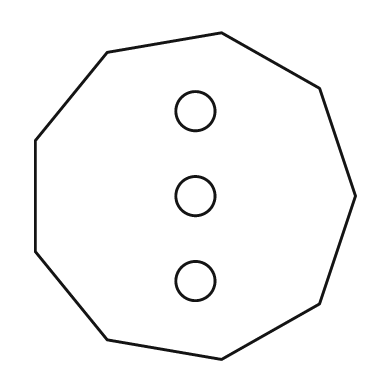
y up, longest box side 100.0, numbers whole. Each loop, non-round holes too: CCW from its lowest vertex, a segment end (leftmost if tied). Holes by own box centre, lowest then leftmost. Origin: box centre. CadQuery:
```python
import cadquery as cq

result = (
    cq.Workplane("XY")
    .moveTo(8.0, -50.0)
    .lineTo(38.0, -33.0)
    .lineTo(49.0, 0.0)
    .lineTo(38.0, 33.0)
    .lineTo(8.0, 50.0)
    .lineTo(-27.0, 44.0)
    .lineTo(-49.0, 17.0)
    .lineTo(-49.0, -17.0)
    .lineTo(-27.0, -44.0)
    .close()
    .moveTo(0.0, -26.0)
    .circle(6.0)
    .moveTo(0.0, 0.0)
    .circle(6.0)
    .moveTo(0.0, 26.0)
    .circle(6.0)
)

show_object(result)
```